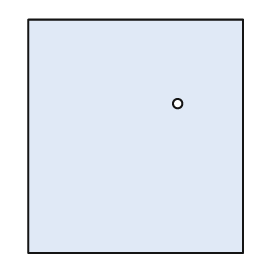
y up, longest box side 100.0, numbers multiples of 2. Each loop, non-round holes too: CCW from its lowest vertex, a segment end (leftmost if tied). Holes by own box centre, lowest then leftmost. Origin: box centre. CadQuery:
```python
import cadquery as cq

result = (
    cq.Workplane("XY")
    .moveTo(-46.0, -50.0)
    .lineTo(46.0, -50.0)
    .lineTo(46.0, 50.0)
    .lineTo(-46.0, 50.0)
    .close()
    .moveTo(18.0, 14.0)
    .circle(2.0)
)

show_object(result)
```